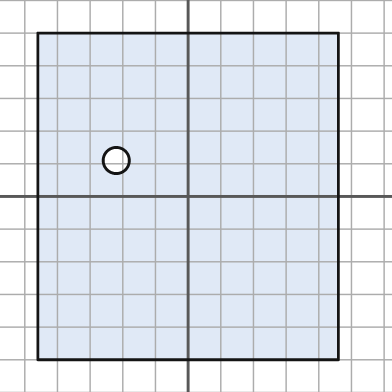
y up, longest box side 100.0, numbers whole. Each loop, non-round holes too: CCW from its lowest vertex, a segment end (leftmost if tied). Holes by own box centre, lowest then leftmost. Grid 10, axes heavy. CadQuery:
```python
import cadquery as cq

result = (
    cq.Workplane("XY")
    .moveTo(-46.0, -50.0)
    .lineTo(46.0, -50.0)
    .lineTo(46.0, 50.0)
    .lineTo(-46.0, 50.0)
    .close()
    .moveTo(-22.0, 11.0)
    .circle(4.0)
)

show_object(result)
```